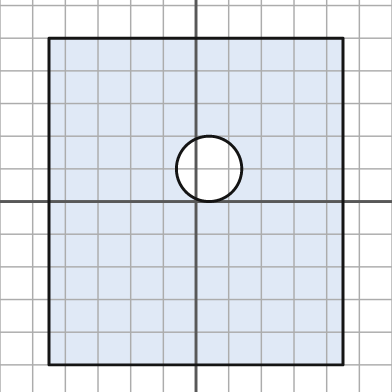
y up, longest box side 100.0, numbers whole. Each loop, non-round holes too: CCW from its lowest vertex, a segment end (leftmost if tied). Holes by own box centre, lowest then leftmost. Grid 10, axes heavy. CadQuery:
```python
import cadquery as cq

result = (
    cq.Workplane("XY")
    .moveTo(-45.0, -50.0)
    .lineTo(45.0, -50.0)
    .lineTo(45.0, 50.0)
    .lineTo(-45.0, 50.0)
    .close()
    .moveTo(4.0, 10.0)
    .circle(10.0)
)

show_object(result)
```